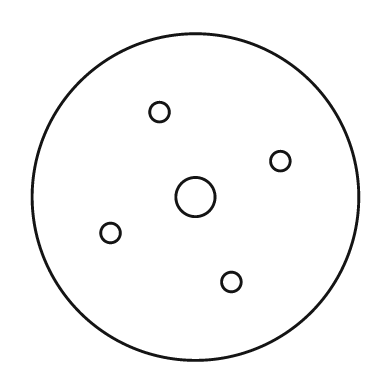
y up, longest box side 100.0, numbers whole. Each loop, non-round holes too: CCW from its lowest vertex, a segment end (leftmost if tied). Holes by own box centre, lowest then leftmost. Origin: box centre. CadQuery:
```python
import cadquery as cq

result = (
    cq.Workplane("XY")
    .moveTo(0.0, 0.0)
    .circle(50.0)
    .moveTo(11.0, -26.0)
    .circle(3.0)
    .moveTo(-26.0, -11.0)
    .circle(3.0)
    .moveTo(0.0, 0.0)
    .circle(6.0)
    .moveTo(26.0, 11.0)
    .circle(3.0)
    .moveTo(-11.0, 26.0)
    .circle(3.0)
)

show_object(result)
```